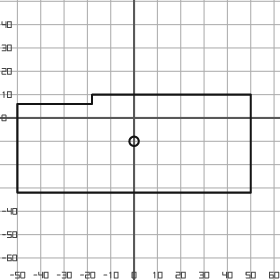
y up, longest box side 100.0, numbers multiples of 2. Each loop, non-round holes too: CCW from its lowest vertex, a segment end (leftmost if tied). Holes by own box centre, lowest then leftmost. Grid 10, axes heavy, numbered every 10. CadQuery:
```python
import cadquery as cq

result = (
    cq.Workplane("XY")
    .moveTo(-50.0, -32.0)
    .lineTo(50.0, -32.0)
    .lineTo(50.0, 10.0)
    .lineTo(-18.0, 10.0)
    .lineTo(-18.0, 6.0)
    .lineTo(-50.0, 6.0)
    .close()
    .moveTo(0.0, -10.0)
    .circle(2.0)
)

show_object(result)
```